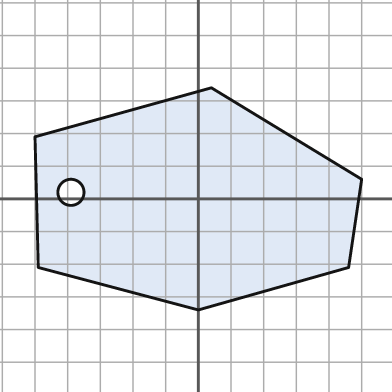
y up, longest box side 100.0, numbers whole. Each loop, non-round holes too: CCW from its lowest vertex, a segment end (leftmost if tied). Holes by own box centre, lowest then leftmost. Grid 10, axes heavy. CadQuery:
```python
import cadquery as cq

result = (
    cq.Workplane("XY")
    .moveTo(0.0, -34.0)
    .lineTo(46.0, -21.0)
    .lineTo(50.0, 6.0)
    .lineTo(4.0, 34.0)
    .lineTo(-50.0, 19.0)
    .lineTo(-49.0, -21.0)
    .close()
    .moveTo(-39.0, 2.0)
    .circle(4.0)
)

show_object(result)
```